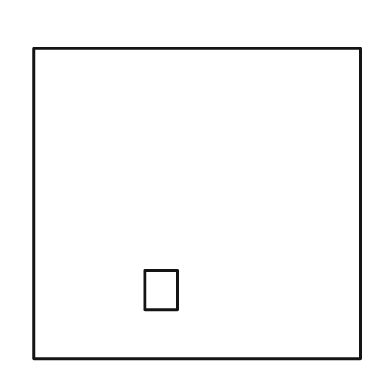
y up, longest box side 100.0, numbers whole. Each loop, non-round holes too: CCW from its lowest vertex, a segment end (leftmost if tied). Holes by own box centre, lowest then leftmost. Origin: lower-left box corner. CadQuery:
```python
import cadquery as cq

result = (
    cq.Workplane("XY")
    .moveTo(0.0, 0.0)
    .lineTo(100.0, 0.0)
    .lineTo(100.0, 95.0)
    .lineTo(0.0, 95.0)
    .close()
    .moveTo(34.0, 15.0)
    .lineTo(44.0, 15.0)
    .lineTo(44.0, 27.0)
    .lineTo(34.0, 27.0)
    .close()
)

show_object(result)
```